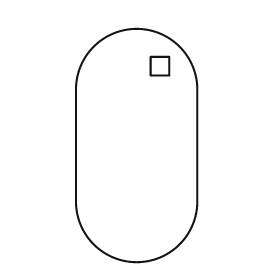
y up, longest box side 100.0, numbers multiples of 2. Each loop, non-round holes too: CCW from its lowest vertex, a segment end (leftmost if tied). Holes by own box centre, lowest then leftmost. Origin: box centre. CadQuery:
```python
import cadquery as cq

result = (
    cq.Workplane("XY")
    .moveTo(-26.0, -24.0)
    .threePointArc((0.0, -50.0), (26.0, -24.0))
    .lineTo(26.0, 24.0)
    .threePointArc((0.0, 50.0), (-26.0, 24.0))
    .close()
    .moveTo(6.0, 30.0)
    .lineTo(14.0, 30.0)
    .lineTo(14.0, 38.0)
    .lineTo(6.0, 38.0)
    .close()
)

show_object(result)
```